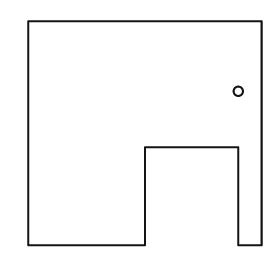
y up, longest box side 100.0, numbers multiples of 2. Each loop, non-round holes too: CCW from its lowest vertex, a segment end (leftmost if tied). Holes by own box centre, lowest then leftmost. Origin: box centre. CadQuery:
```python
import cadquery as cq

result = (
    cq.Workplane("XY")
    .moveTo(-50.0, -48.0)
    .lineTo(0.0, -48.0)
    .lineTo(0.0, -6.0)
    .lineTo(40.0, -6.0)
    .lineTo(40.0, -48.0)
    .lineTo(50.0, -48.0)
    .lineTo(50.0, 48.0)
    .lineTo(-50.0, 48.0)
    .close()
    .moveTo(40.0, 18.0)
    .circle(2.0)
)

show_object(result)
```